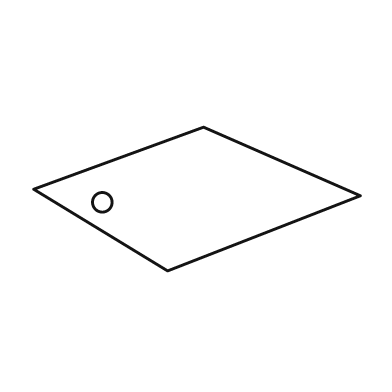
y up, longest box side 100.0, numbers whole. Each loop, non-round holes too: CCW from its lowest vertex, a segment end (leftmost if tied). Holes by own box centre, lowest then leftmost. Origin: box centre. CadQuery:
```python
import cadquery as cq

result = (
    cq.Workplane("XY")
    .moveTo(-9.0, -22.0)
    .lineTo(50.0, 1.0)
    .lineTo(2.0, 22.0)
    .lineTo(-50.0, 3.0)
    .close()
    .moveTo(-29.0, -1.0)
    .circle(3.0)
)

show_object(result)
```